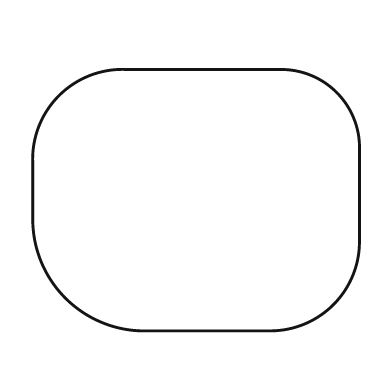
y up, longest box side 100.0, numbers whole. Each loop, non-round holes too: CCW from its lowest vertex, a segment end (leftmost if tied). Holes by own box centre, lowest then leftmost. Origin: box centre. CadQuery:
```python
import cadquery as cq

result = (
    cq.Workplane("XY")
    .moveTo(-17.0, -40.0)
    .lineTo(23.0, -40.0)
    .threePointArc((42.0, -32.0), (50.0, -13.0))
    .lineTo(50.0, 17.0)
    .threePointArc((43.0, 33.0), (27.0, 40.0))
    .lineTo(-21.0, 40.0)
    .threePointArc((-42.0, 32.0), (-50.0, 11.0))
    .lineTo(-50.0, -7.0)
    .threePointArc((-40.0, -30.0), (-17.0, -40.0))
    .close()
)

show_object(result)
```